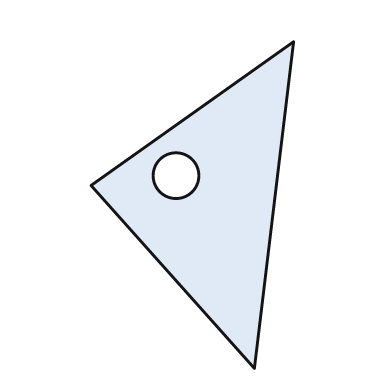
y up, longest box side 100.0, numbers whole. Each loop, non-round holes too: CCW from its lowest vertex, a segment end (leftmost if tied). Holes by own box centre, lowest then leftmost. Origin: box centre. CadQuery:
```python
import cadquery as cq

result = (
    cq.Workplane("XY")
    .moveTo(19.0, -50.0)
    .lineTo(31.0, 50.0)
    .lineTo(-31.0, 6.0)
    .close()
    .moveTo(-5.0, 9.0)
    .circle(7.0)
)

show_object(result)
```